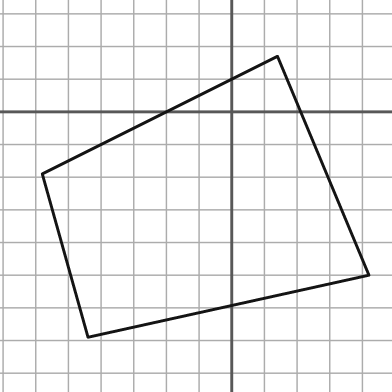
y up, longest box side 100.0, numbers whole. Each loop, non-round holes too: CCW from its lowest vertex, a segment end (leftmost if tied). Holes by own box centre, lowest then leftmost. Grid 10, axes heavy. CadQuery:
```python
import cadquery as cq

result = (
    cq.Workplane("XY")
    .moveTo(-44.0, -69.0)
    .lineTo(42.0, -50.0)
    .lineTo(14.0, 17.0)
    .lineTo(-58.0, -19.0)
    .close()
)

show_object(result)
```